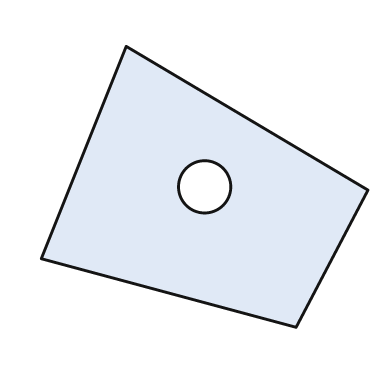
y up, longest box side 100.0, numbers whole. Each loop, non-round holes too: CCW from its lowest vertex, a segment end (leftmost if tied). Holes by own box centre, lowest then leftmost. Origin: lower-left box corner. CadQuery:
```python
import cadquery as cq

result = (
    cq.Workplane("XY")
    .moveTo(78.0, 0.0)
    .lineTo(100.0, 42.0)
    .lineTo(26.0, 86.0)
    .lineTo(0.0, 21.0)
    .close()
    .moveTo(50.0, 43.0)
    .circle(8.0)
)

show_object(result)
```